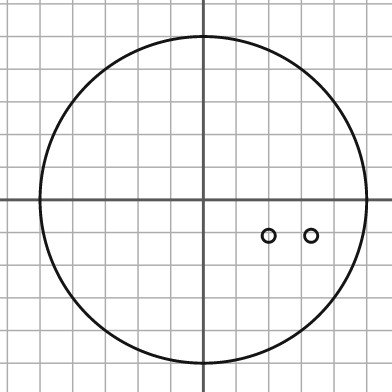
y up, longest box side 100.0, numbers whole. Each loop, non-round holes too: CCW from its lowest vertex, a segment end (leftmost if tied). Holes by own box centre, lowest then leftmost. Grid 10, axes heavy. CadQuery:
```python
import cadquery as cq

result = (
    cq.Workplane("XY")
    .moveTo(0.0, 0.0)
    .circle(50.0)
    .moveTo(20.0, -11.0)
    .circle(2.0)
    .moveTo(33.0, -11.0)
    .circle(2.0)
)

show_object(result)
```